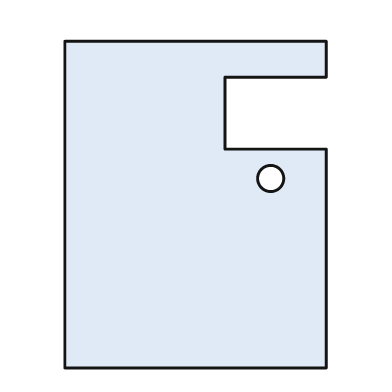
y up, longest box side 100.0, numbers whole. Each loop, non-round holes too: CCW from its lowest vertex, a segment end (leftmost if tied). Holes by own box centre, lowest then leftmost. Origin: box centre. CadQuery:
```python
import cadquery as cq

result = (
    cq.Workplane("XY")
    .moveTo(-40.0, -50.0)
    .lineTo(40.0, -50.0)
    .lineTo(40.0, 17.0)
    .lineTo(9.0, 17.0)
    .lineTo(9.0, 39.0)
    .lineTo(40.0, 39.0)
    .lineTo(40.0, 50.0)
    .lineTo(-40.0, 50.0)
    .close()
    .moveTo(23.0, 8.0)
    .circle(4.0)
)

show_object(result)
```